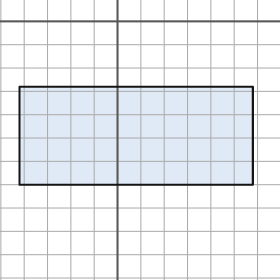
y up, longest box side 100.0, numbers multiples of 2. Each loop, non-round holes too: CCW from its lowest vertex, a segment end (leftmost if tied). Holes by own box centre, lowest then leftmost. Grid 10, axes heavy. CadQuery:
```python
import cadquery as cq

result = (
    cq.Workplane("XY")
    .moveTo(-42.0, -70.0)
    .lineTo(58.0, -70.0)
    .lineTo(58.0, -28.0)
    .lineTo(-42.0, -28.0)
    .close()
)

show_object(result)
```